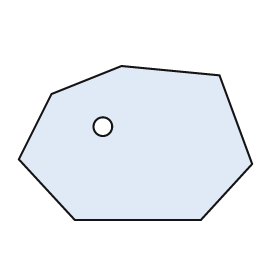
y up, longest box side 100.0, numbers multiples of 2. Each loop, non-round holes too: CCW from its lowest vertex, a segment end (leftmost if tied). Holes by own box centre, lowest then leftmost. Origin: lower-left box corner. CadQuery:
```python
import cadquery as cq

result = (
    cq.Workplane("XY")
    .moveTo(24.0, 0.0)
    .lineTo(78.0, 0.0)
    .lineTo(100.0, 24.0)
    .lineTo(86.0, 62.0)
    .lineTo(44.0, 66.0)
    .lineTo(14.0, 54.0)
    .lineTo(0.0, 26.0)
    .close()
    .moveTo(36.0, 40.0)
    .circle(4.0)
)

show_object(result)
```